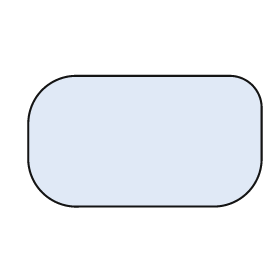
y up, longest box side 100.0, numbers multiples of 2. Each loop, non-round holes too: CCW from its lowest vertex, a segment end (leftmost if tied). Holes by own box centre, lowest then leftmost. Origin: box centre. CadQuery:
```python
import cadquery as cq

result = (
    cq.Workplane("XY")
    .moveTo(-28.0, -28.0)
    .lineTo(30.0, -28.0)
    .threePointArc((44.0, -22.0), (50.0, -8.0))
    .lineTo(50.0, 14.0)
    .threePointArc((46.0, 24.0), (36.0, 28.0))
    .lineTo(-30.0, 28.0)
    .threePointArc((-44.0, 22.0), (-50.0, 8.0))
    .lineTo(-50.0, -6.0)
    .threePointArc((-44.0, -22.0), (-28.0, -28.0))
    .close()
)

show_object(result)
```